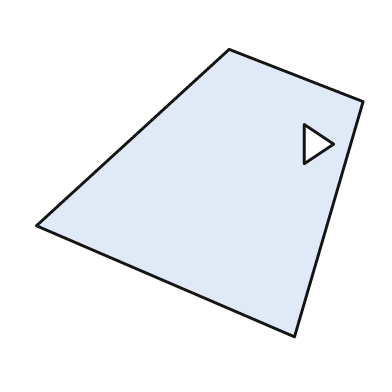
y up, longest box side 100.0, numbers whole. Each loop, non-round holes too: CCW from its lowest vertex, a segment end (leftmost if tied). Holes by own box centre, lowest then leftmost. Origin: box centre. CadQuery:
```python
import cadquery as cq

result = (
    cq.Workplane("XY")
    .moveTo(29.0, -44.0)
    .lineTo(50.0, 28.0)
    .lineTo(9.0, 44.0)
    .lineTo(-50.0, -10.0)
    .close()
    .moveTo(32.0, 9.0)
    .lineTo(41.0, 15.0)
    .lineTo(32.0, 21.0)
    .close()
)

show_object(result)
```